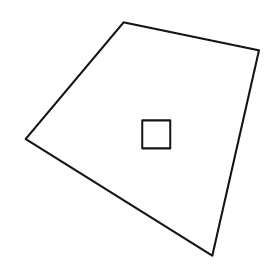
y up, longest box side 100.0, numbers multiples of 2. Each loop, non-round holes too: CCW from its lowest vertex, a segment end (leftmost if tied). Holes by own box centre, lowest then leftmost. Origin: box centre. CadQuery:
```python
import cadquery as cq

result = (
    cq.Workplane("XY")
    .moveTo(30.0, -50.0)
    .lineTo(50.0, 38.0)
    .lineTo(-8.0, 50.0)
    .lineTo(-50.0, 0.0)
    .close()
    .moveTo(0.0, -4.0)
    .lineTo(12.0, -4.0)
    .lineTo(12.0, 8.0)
    .lineTo(0.0, 8.0)
    .close()
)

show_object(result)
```